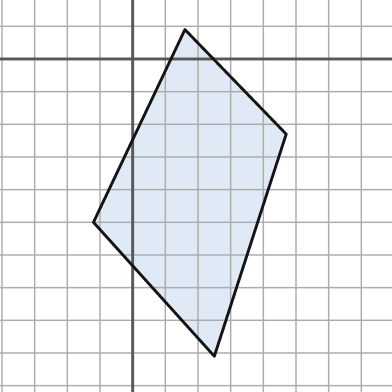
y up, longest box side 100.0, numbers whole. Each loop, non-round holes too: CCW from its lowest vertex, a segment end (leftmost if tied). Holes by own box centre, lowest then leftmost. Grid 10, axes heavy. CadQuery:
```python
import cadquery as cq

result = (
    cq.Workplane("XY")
    .moveTo(25.0, -91.0)
    .lineTo(47.0, -23.0)
    .lineTo(16.0, 9.0)
    .lineTo(-12.0, -50.0)
    .close()
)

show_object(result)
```